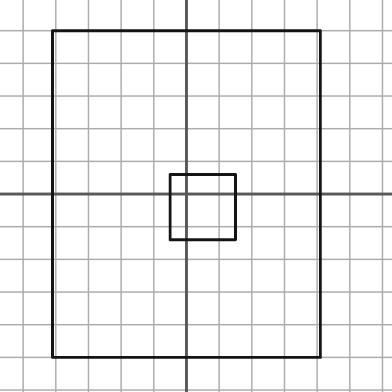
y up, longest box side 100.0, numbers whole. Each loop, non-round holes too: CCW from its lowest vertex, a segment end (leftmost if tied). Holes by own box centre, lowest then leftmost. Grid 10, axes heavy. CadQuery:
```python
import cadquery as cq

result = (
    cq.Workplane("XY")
    .moveTo(-41.0, -50.0)
    .lineTo(41.0, -50.0)
    .lineTo(41.0, 50.0)
    .lineTo(-41.0, 50.0)
    .close()
    .moveTo(-5.0, -14.0)
    .lineTo(15.0, -14.0)
    .lineTo(15.0, 6.0)
    .lineTo(-5.0, 6.0)
    .close()
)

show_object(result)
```